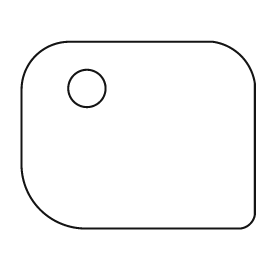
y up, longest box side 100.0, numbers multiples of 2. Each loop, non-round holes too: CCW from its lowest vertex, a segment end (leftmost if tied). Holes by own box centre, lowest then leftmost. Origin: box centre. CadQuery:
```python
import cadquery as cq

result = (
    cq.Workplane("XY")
    .moveTo(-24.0, -40.0)
    .lineTo(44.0, -40.0)
    .threePointArc((48.0, -38.0), (50.0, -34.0))
    .lineTo(50.0, 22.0)
    .threePointArc((44.0, 34.0), (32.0, 40.0))
    .lineTo(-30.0, 40.0)
    .threePointArc((-44.0, 34.0), (-50.0, 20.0))
    .lineTo(-50.0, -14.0)
    .threePointArc((-42.0, -32.0), (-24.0, -40.0))
    .close()
    .moveTo(-22.0, 20.0)
    .circle(8.0)
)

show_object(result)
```